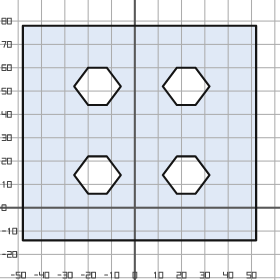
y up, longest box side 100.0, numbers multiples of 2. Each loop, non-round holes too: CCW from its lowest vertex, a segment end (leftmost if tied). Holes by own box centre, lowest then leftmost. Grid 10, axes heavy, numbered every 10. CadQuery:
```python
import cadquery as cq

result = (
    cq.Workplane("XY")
    .moveTo(-48.0, -14.0)
    .lineTo(52.0, -14.0)
    .lineTo(52.0, 78.0)
    .lineTo(-48.0, 78.0)
    .close()
    .moveTo(-20.0, 6.0)
    .lineTo(-12.0, 6.0)
    .lineTo(-6.0, 14.0)
    .lineTo(-12.0, 22.0)
    .lineTo(-20.0, 22.0)
    .lineTo(-26.0, 14.0)
    .close()
    .moveTo(18.0, 6.0)
    .lineTo(26.0, 6.0)
    .lineTo(32.0, 14.0)
    .lineTo(26.0, 22.0)
    .lineTo(18.0, 22.0)
    .lineTo(12.0, 14.0)
    .close()
    .moveTo(-20.0, 44.0)
    .lineTo(-12.0, 44.0)
    .lineTo(-6.0, 52.0)
    .lineTo(-12.0, 60.0)
    .lineTo(-20.0, 60.0)
    .lineTo(-26.0, 52.0)
    .close()
    .moveTo(18.0, 44.0)
    .lineTo(26.0, 44.0)
    .lineTo(32.0, 52.0)
    .lineTo(26.0, 60.0)
    .lineTo(18.0, 60.0)
    .lineTo(12.0, 52.0)
    .close()
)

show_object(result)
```